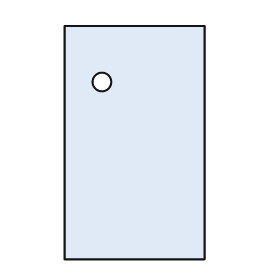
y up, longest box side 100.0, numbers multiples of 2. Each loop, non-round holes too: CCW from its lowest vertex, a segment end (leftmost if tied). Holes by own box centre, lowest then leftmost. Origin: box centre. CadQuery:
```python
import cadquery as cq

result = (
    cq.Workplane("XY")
    .moveTo(-30.0, -50.0)
    .lineTo(30.0, -50.0)
    .lineTo(30.0, 50.0)
    .lineTo(-30.0, 50.0)
    .close()
    .moveTo(-14.0, 26.0)
    .circle(4.0)
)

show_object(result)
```